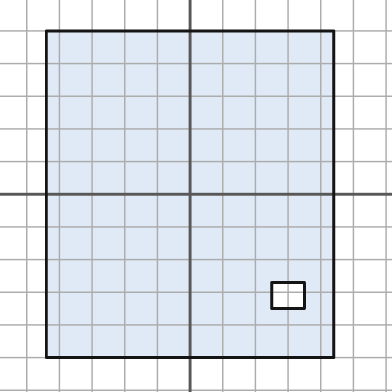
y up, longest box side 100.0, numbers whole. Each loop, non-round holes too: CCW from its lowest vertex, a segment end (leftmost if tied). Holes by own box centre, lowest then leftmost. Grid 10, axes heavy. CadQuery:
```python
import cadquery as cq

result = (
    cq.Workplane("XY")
    .moveTo(-44.0, -50.0)
    .lineTo(44.0, -50.0)
    .lineTo(44.0, 50.0)
    .lineTo(-44.0, 50.0)
    .close()
    .moveTo(25.0, -35.0)
    .lineTo(35.0, -35.0)
    .lineTo(35.0, -27.0)
    .lineTo(25.0, -27.0)
    .close()
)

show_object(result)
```